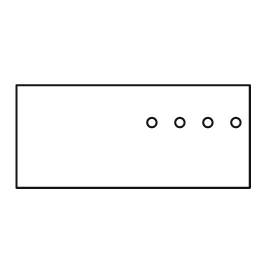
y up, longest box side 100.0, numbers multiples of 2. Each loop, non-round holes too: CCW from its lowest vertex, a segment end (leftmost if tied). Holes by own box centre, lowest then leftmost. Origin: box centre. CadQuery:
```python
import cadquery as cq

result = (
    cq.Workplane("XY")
    .moveTo(-50.0, -22.0)
    .lineTo(50.0, -22.0)
    .lineTo(50.0, 22.0)
    .lineTo(-50.0, 22.0)
    .close()
    .moveTo(8.0, 6.0)
    .circle(2.0)
    .moveTo(20.0, 6.0)
    .circle(2.0)
    .moveTo(32.0, 6.0)
    .circle(2.0)
    .moveTo(44.0, 6.0)
    .circle(2.0)
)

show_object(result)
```